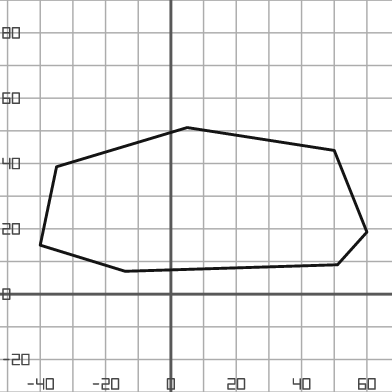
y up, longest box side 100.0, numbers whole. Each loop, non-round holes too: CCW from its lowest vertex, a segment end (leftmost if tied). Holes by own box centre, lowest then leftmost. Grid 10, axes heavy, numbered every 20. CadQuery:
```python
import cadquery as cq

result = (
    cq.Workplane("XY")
    .moveTo(-14.0, 7.0)
    .lineTo(51.0, 9.0)
    .lineTo(60.0, 19.0)
    .lineTo(50.0, 44.0)
    .lineTo(5.0, 51.0)
    .lineTo(-35.0, 39.0)
    .lineTo(-40.0, 15.0)
    .close()
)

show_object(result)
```